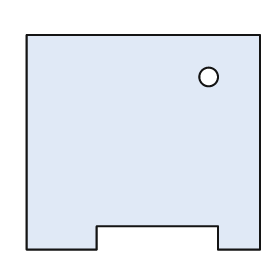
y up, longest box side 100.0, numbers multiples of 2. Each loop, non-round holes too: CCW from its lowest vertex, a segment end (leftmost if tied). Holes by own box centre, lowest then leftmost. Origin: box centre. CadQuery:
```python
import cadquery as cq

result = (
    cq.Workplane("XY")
    .moveTo(-50.0, -46.0)
    .lineTo(-20.0, -46.0)
    .lineTo(-20.0, -36.0)
    .lineTo(32.0, -36.0)
    .lineTo(32.0, -46.0)
    .lineTo(50.0, -46.0)
    .lineTo(50.0, 46.0)
    .lineTo(-50.0, 46.0)
    .close()
    .moveTo(28.0, 28.0)
    .circle(4.0)
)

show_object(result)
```